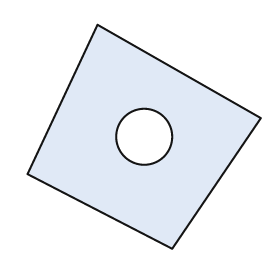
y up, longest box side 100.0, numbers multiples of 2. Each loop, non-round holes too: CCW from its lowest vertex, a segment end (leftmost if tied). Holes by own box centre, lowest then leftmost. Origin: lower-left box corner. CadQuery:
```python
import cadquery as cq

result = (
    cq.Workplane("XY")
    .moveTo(62.0, 0.0)
    .lineTo(100.0, 56.0)
    .lineTo(30.0, 96.0)
    .lineTo(0.0, 32.0)
    .close()
    .moveTo(50.0, 48.0)
    .circle(12.0)
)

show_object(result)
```